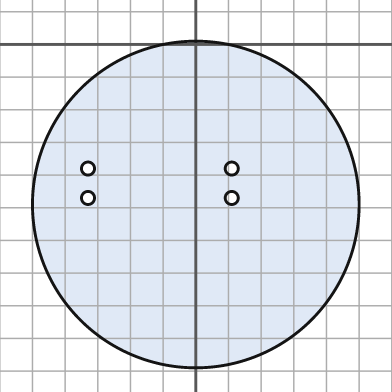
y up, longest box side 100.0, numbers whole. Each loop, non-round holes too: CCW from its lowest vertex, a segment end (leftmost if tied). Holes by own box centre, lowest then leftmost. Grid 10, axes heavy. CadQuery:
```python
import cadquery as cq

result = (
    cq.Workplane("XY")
    .moveTo(0.0, -49.0)
    .circle(50.0)
    .moveTo(-33.0, -47.0)
    .circle(2.0)
    .moveTo(11.0, -47.0)
    .circle(2.0)
    .moveTo(-33.0, -38.0)
    .circle(2.0)
    .moveTo(11.0, -38.0)
    .circle(2.0)
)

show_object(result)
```